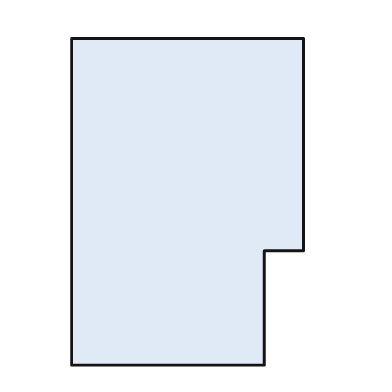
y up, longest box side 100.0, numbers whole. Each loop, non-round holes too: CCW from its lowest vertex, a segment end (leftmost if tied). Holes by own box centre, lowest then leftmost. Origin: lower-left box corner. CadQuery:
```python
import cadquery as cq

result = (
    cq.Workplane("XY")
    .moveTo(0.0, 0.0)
    .lineTo(59.0, 0.0)
    .lineTo(59.0, 35.0)
    .lineTo(71.0, 35.0)
    .lineTo(71.0, 100.0)
    .lineTo(0.0, 100.0)
    .close()
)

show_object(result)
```